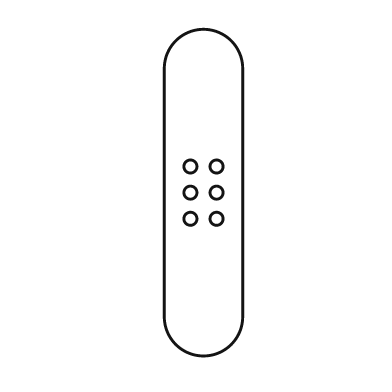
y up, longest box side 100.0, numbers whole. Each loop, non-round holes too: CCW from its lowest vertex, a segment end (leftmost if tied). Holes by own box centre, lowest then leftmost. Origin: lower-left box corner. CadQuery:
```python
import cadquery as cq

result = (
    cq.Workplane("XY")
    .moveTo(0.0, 12.0)
    .threePointArc((12.0, 0.0), (24.0, 12.0))
    .lineTo(24.0, 88.0)
    .threePointArc((12.0, 100.0), (0.0, 88.0))
    .close()
    .moveTo(8.0, 42.0)
    .circle(2.0)
    .moveTo(16.0, 42.0)
    .circle(2.0)
    .moveTo(8.0, 50.0)
    .circle(2.0)
    .moveTo(16.0, 50.0)
    .circle(2.0)
    .moveTo(8.0, 58.0)
    .circle(2.0)
    .moveTo(16.0, 58.0)
    .circle(2.0)
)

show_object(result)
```